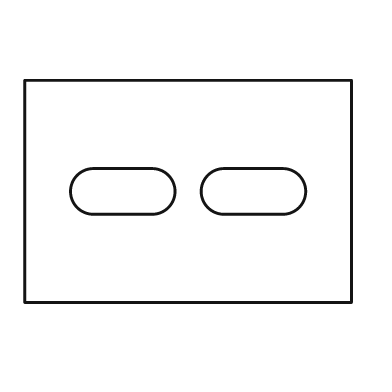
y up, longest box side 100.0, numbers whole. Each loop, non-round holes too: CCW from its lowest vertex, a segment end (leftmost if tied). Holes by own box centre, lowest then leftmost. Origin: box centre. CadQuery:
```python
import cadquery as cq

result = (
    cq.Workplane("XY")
    .moveTo(-50.0, -34.0)
    .lineTo(50.0, -34.0)
    .lineTo(50.0, 34.0)
    .lineTo(-50.0, 34.0)
    .close()
    .moveTo(-29.0, -7.0)
    .lineTo(-11.0, -7.0)
    .threePointArc((-4.0, 0.0), (-11.0, 7.0))
    .lineTo(-29.0, 7.0)
    .threePointArc((-36.0, 0.0), (-29.0, -7.0))
    .close()
    .moveTo(11.0, -7.0)
    .lineTo(29.0, -7.0)
    .threePointArc((36.0, 0.0), (29.0, 7.0))
    .lineTo(11.0, 7.0)
    .threePointArc((4.0, 0.0), (11.0, -7.0))
    .close()
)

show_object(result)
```